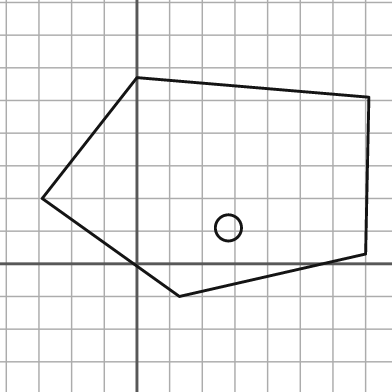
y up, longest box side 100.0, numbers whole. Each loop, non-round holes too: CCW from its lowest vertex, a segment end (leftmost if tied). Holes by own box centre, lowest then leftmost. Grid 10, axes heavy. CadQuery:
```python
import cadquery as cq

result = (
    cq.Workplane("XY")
    .moveTo(13.0, -10.0)
    .lineTo(70.0, 3.0)
    .lineTo(71.0, 51.0)
    .lineTo(0.0, 57.0)
    .lineTo(-29.0, 20.0)
    .close()
    .moveTo(28.0, 11.0)
    .circle(4.0)
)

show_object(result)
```